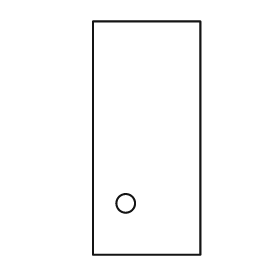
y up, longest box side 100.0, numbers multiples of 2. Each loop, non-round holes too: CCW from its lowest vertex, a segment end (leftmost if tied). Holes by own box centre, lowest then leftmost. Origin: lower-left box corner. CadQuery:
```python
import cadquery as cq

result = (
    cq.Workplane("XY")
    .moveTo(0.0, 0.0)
    .lineTo(46.0, 0.0)
    .lineTo(46.0, 100.0)
    .lineTo(0.0, 100.0)
    .close()
    .moveTo(14.0, 22.0)
    .circle(4.0)
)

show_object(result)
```